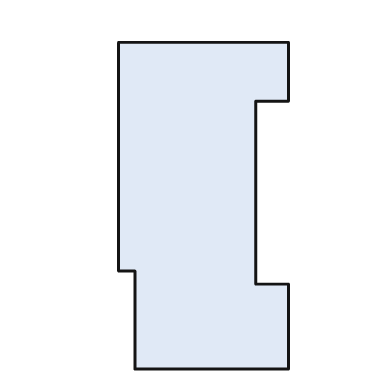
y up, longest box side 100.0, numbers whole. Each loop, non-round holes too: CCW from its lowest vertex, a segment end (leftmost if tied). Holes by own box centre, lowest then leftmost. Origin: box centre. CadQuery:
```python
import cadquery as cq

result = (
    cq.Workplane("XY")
    .moveTo(-21.0, -50.0)
    .lineTo(26.0, -50.0)
    .lineTo(26.0, -24.0)
    .lineTo(16.0, -24.0)
    .lineTo(16.0, 32.0)
    .lineTo(26.0, 32.0)
    .lineTo(26.0, 50.0)
    .lineTo(-26.0, 50.0)
    .lineTo(-26.0, -20.0)
    .lineTo(-21.0, -20.0)
    .close()
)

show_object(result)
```